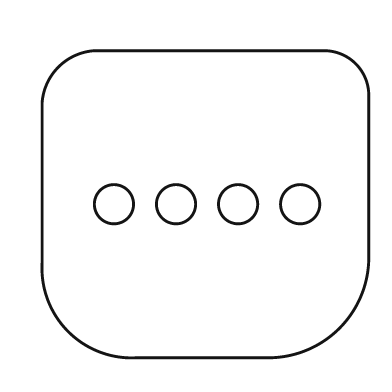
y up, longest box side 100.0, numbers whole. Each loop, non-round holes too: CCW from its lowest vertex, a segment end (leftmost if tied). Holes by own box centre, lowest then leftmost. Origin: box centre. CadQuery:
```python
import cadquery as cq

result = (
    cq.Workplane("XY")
    .moveTo(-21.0, -47.0)
    .lineTo(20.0, -47.0)
    .threePointArc((41.0, -38.0), (50.0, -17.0))
    .lineTo(50.0, 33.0)
    .threePointArc((46.0, 43.0), (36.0, 47.0))
    .lineTo(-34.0, 47.0)
    .threePointArc((-45.0, 42.0), (-50.0, 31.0))
    .lineTo(-50.0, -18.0)
    .threePointArc((-42.0, -39.0), (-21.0, -47.0))
    .close()
    .moveTo(-28.0, 0.0)
    .circle(6.0)
    .moveTo(-9.0, 0.0)
    .circle(6.0)
    .moveTo(10.0, 0.0)
    .circle(6.0)
    .moveTo(29.0, 0.0)
    .circle(6.0)
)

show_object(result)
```